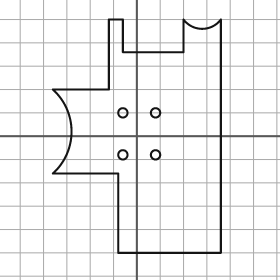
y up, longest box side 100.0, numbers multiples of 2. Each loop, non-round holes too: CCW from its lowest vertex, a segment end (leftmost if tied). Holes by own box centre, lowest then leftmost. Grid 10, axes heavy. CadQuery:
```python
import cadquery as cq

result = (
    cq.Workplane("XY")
    .moveTo(-8.0, -50.0)
    .lineTo(36.0, -50.0)
    .lineTo(36.0, 50.0)
    .threePointArc((28.0, 46.0), (20.0, 50.0))
    .lineTo(20.0, 36.0)
    .lineTo(-6.0, 36.0)
    .lineTo(-6.0, 50.0)
    .lineTo(-12.0, 50.0)
    .lineTo(-12.0, 20.0)
    .lineTo(-36.0, 20.0)
    .threePointArc((-28.0, 2.0), (-36.0, -16.0))
    .lineTo(-8.0, -16.0)
    .close()
    .moveTo(-6.0, -8.0)
    .circle(2.0)
    .moveTo(8.0, -8.0)
    .circle(2.0)
    .moveTo(-6.0, 10.0)
    .circle(2.0)
    .moveTo(8.0, 10.0)
    .circle(2.0)
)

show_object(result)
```